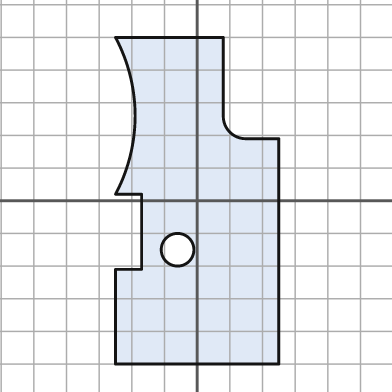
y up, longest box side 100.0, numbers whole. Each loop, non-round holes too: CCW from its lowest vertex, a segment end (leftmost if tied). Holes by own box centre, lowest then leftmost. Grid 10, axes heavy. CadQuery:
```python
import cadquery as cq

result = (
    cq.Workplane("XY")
    .moveTo(-25.0, -50.0)
    .lineTo(25.0, -50.0)
    .lineTo(25.0, 19.0)
    .lineTo(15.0, 19.0)
    .threePointArc((10.0, 21.0), (8.0, 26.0))
    .lineTo(8.0, 50.0)
    .lineTo(-25.0, 50.0)
    .threePointArc((-19.0, 26.0), (-25.0, 2.0))
    .lineTo(-17.0, 2.0)
    .lineTo(-17.0, -21.0)
    .lineTo(-25.0, -21.0)
    .close()
    .moveTo(-6.0, -15.0)
    .circle(5.0)
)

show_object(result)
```